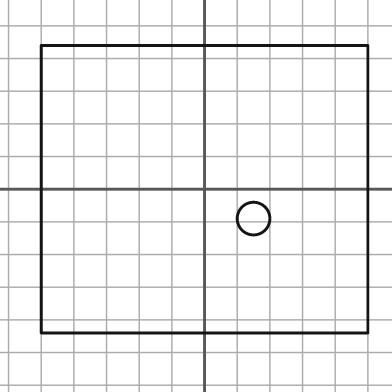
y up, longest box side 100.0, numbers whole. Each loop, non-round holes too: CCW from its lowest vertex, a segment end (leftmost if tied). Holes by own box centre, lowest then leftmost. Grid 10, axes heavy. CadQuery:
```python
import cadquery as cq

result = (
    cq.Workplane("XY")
    .moveTo(-50.0, -44.0)
    .lineTo(50.0, -44.0)
    .lineTo(50.0, 44.0)
    .lineTo(-50.0, 44.0)
    .close()
    .moveTo(15.0, -9.0)
    .circle(5.0)
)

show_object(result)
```